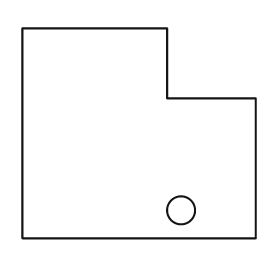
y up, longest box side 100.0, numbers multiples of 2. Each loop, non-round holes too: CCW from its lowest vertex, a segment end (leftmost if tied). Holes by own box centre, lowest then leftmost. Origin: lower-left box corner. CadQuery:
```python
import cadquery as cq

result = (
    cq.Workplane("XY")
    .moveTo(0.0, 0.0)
    .lineTo(100.0, 0.0)
    .lineTo(100.0, 60.0)
    .lineTo(62.0, 60.0)
    .lineTo(62.0, 90.0)
    .lineTo(0.0, 90.0)
    .close()
    .moveTo(68.0, 12.0)
    .circle(6.0)
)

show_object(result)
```